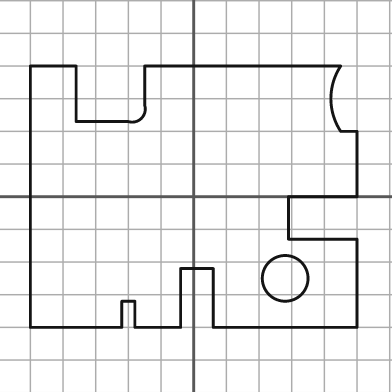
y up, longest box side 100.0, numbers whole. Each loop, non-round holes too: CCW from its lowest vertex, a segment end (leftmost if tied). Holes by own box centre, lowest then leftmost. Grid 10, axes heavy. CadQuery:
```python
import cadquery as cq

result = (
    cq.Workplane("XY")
    .moveTo(-50.0, -40.0)
    .lineTo(-22.0, -40.0)
    .lineTo(-22.0, -32.0)
    .lineTo(-18.0, -32.0)
    .lineTo(-18.0, -40.0)
    .lineTo(-4.0, -40.0)
    .lineTo(-4.0, -22.0)
    .lineTo(6.0, -22.0)
    .lineTo(6.0, -40.0)
    .lineTo(50.0, -40.0)
    .lineTo(50.0, -13.0)
    .lineTo(29.0, -13.0)
    .lineTo(29.0, 0.0)
    .lineTo(50.0, 0.0)
    .lineTo(50.0, 20.0)
    .lineTo(45.0, 20.0)
    .threePointArc((42.0, 30.0), (45.0, 40.0))
    .lineTo(-15.0, 40.0)
    .lineTo(-15.0, 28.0)
    .threePointArc((-16.0, 24.0), (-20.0, 23.0))
    .lineTo(-36.0, 23.0)
    .lineTo(-36.0, 40.0)
    .lineTo(-50.0, 40.0)
    .close()
    .moveTo(28.0, -25.0)
    .circle(7.0)
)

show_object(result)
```